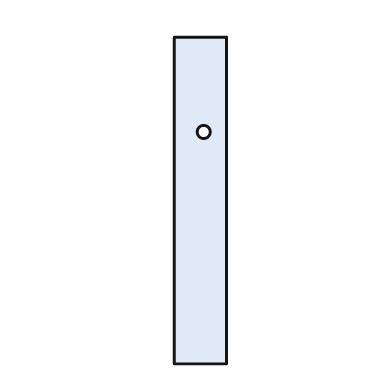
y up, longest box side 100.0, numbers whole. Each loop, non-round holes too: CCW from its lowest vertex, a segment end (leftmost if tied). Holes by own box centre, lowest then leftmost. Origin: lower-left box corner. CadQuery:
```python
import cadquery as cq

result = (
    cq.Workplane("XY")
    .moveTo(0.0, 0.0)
    .lineTo(16.0, 0.0)
    .lineTo(16.0, 100.0)
    .lineTo(0.0, 100.0)
    .close()
    .moveTo(9.0, 71.0)
    .circle(2.0)
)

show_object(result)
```